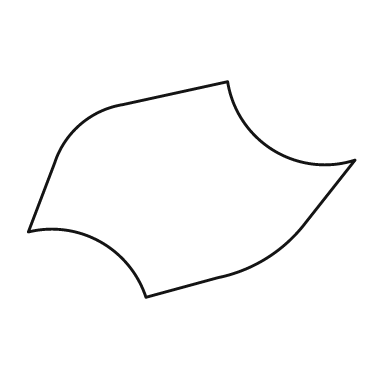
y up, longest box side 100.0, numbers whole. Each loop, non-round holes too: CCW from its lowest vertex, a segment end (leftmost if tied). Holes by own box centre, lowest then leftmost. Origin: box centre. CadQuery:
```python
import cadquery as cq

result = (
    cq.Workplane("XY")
    .moveTo(-14.0, -33.0)
    .lineTo(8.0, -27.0)
    .threePointArc((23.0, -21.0), (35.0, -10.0))
    .lineTo(50.0, 9.0)
    .threePointArc((25.0, 12.0), (11.0, 33.0))
    .lineTo(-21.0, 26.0)
    .threePointArc((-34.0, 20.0), (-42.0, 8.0))
    .lineTo(-50.0, -13.0)
    .threePointArc((-28.0, -16.0), (-14.0, -33.0))
    .close()
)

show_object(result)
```